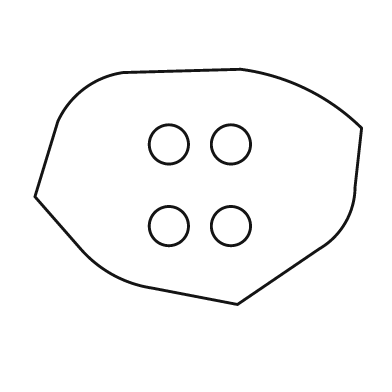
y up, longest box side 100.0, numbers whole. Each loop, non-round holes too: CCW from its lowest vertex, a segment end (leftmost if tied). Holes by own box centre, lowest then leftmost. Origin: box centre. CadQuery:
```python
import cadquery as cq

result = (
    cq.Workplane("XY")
    .moveTo(12.0, -36.0)
    .lineTo(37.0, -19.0)
    .threePointArc((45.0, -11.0), (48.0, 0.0))
    .lineTo(50.0, 18.0)
    .threePointArc((33.0, 30.0), (13.0, 36.0))
    .lineTo(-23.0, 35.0)
    .threePointArc((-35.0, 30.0), (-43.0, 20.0))
    .lineTo(-50.0, -3.0)
    .lineTo(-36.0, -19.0)
    .threePointArc((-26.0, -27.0), (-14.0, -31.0))
    .close()
    .moveTo(-9.0, -12.0)
    .circle(6.0)
    .moveTo(10.0, -12.0)
    .circle(6.0)
    .moveTo(-9.0, 13.0)
    .circle(6.0)
    .moveTo(10.0, 13.0)
    .circle(6.0)
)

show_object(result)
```